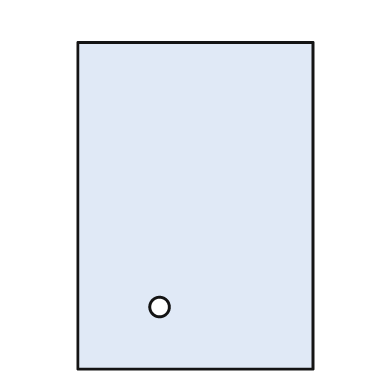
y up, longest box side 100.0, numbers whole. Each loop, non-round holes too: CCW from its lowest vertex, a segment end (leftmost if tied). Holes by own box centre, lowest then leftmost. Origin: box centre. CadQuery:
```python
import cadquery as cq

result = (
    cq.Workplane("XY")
    .moveTo(-36.0, -50.0)
    .lineTo(36.0, -50.0)
    .lineTo(36.0, 50.0)
    .lineTo(-36.0, 50.0)
    .close()
    .moveTo(-11.0, -31.0)
    .circle(3.0)
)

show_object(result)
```